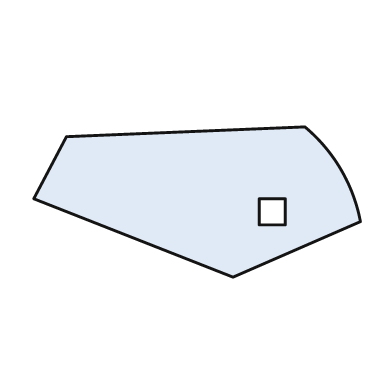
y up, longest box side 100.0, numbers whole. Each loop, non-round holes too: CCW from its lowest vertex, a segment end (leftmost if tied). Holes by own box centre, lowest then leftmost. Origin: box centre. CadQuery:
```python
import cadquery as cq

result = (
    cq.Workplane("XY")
    .moveTo(11.0, -23.0)
    .lineTo(50.0, -6.0)
    .threePointArc((44.0, 10.0), (33.0, 23.0))
    .lineTo(-40.0, 20.0)
    .lineTo(-50.0, 1.0)
    .close()
    .moveTo(19.0, -7.0)
    .lineTo(27.0, -7.0)
    .lineTo(27.0, 1.0)
    .lineTo(19.0, 1.0)
    .close()
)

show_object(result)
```